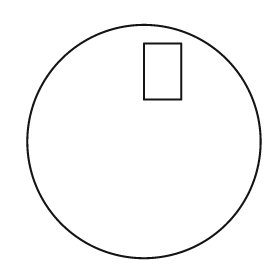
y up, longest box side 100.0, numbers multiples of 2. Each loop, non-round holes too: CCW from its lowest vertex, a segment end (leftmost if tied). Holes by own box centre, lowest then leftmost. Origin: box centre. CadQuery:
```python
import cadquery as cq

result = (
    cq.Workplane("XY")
    .moveTo(0.0, 0.0)
    .circle(50.0)
    .moveTo(0.0, 18.0)
    .lineTo(16.0, 18.0)
    .lineTo(16.0, 42.0)
    .lineTo(0.0, 42.0)
    .close()
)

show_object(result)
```